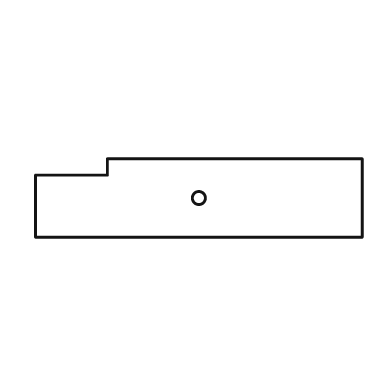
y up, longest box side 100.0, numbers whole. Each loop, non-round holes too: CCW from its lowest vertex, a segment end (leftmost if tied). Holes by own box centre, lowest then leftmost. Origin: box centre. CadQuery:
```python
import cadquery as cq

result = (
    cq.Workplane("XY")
    .moveTo(-50.0, -12.0)
    .lineTo(50.0, -12.0)
    .lineTo(50.0, 12.0)
    .lineTo(-28.0, 12.0)
    .lineTo(-28.0, 7.0)
    .lineTo(-50.0, 7.0)
    .close()
    .moveTo(0.0, 0.0)
    .circle(2.0)
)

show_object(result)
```